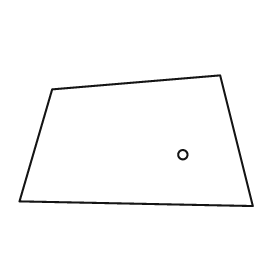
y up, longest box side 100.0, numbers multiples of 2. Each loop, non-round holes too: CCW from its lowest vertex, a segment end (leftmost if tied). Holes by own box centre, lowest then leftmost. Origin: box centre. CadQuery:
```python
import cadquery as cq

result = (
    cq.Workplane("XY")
    .moveTo(50.0, -28.0)
    .lineTo(36.0, 28.0)
    .lineTo(-36.0, 22.0)
    .lineTo(-50.0, -26.0)
    .close()
    .moveTo(20.0, -6.0)
    .circle(2.0)
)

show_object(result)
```